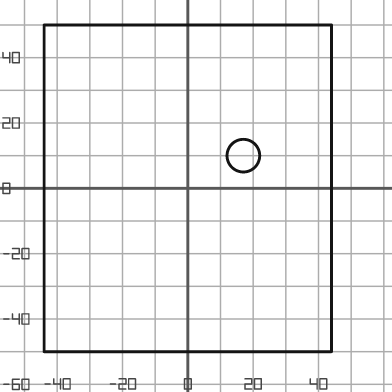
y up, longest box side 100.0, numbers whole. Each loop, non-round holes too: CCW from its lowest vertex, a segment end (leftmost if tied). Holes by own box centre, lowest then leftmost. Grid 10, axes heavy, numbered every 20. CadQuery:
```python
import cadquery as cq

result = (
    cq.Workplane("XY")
    .moveTo(-44.0, -50.0)
    .lineTo(44.0, -50.0)
    .lineTo(44.0, 50.0)
    .lineTo(-44.0, 50.0)
    .close()
    .moveTo(17.0, 10.0)
    .circle(5.0)
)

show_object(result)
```